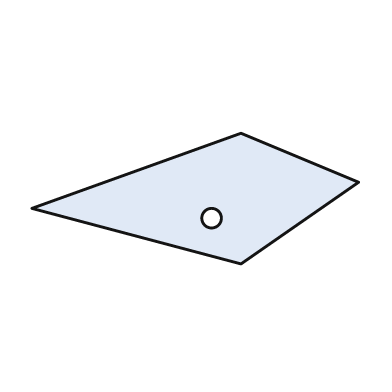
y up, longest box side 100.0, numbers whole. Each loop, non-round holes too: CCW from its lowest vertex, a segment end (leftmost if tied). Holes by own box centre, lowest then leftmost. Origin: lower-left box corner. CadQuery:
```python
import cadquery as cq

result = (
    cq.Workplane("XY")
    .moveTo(64.0, 0.0)
    .lineTo(100.0, 25.0)
    .lineTo(64.0, 40.0)
    .lineTo(0.0, 17.0)
    .close()
    .moveTo(55.0, 14.0)
    .circle(3.0)
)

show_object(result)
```